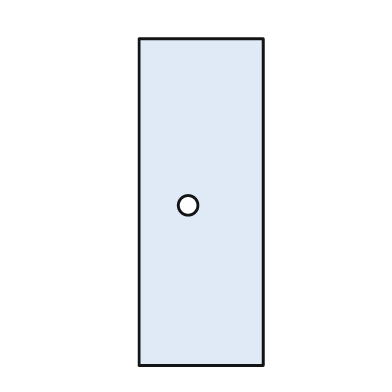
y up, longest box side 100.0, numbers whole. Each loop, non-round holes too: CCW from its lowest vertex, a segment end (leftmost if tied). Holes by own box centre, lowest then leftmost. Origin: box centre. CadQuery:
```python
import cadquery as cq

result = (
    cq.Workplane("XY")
    .moveTo(-19.0, -50.0)
    .lineTo(19.0, -50.0)
    .lineTo(19.0, 50.0)
    .lineTo(-19.0, 50.0)
    .close()
    .moveTo(-4.0, -1.0)
    .circle(3.0)
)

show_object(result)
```